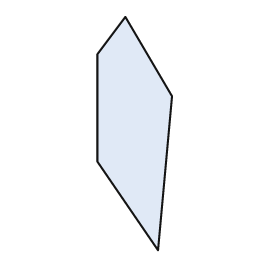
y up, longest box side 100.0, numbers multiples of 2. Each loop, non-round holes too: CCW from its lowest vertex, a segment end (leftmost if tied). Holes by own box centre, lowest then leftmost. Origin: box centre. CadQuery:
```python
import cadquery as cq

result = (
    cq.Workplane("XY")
    .moveTo(10.0, -50.0)
    .lineTo(16.0, 16.0)
    .lineTo(-4.0, 50.0)
    .lineTo(-16.0, 34.0)
    .lineTo(-16.0, -12.0)
    .close()
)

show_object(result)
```